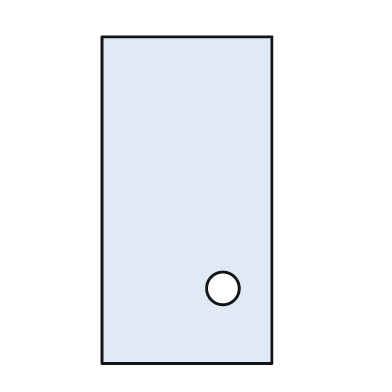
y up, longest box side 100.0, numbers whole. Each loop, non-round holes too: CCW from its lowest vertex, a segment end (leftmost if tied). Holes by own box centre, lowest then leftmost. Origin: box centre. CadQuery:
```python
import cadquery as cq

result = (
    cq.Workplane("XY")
    .moveTo(-26.0, -50.0)
    .lineTo(26.0, -50.0)
    .lineTo(26.0, 50.0)
    .lineTo(-26.0, 50.0)
    .close()
    .moveTo(11.0, -27.0)
    .circle(5.0)
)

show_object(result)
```